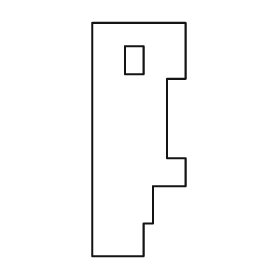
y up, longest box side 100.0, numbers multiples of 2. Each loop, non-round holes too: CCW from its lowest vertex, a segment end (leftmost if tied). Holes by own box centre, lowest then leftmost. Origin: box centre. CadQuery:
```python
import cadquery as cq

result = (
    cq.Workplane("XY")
    .moveTo(-20.0, -50.0)
    .lineTo(2.0, -50.0)
    .lineTo(2.0, -36.0)
    .lineTo(6.0, -36.0)
    .lineTo(6.0, -20.0)
    .lineTo(20.0, -20.0)
    .lineTo(20.0, -8.0)
    .lineTo(12.0, -8.0)
    .lineTo(12.0, 26.0)
    .lineTo(20.0, 26.0)
    .lineTo(20.0, 50.0)
    .lineTo(-20.0, 50.0)
    .close()
    .moveTo(-6.0, 28.0)
    .lineTo(2.0, 28.0)
    .lineTo(2.0, 40.0)
    .lineTo(-6.0, 40.0)
    .close()
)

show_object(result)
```